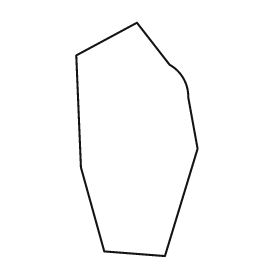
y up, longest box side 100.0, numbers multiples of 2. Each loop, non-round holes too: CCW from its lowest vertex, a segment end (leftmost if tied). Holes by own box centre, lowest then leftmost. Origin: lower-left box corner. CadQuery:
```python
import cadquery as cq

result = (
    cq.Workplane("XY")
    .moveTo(38.0, 0.0)
    .lineTo(52.0, 46.0)
    .lineTo(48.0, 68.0)
    .threePointArc((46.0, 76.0), (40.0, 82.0))
    .lineTo(26.0, 100.0)
    .lineTo(0.0, 86.0)
    .lineTo(2.0, 38.0)
    .lineTo(12.0, 2.0)
    .close()
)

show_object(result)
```